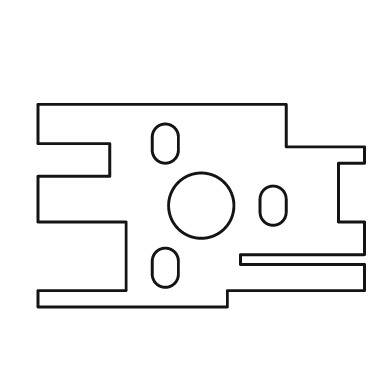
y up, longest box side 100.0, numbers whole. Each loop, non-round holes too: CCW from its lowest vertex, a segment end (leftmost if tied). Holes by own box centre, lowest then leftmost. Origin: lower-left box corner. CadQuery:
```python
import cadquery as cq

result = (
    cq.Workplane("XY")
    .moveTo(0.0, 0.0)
    .lineTo(58.0, 0.0)
    .lineTo(58.0, 5.0)
    .lineTo(100.0, 5.0)
    .lineTo(100.0, 13.0)
    .lineTo(62.0, 13.0)
    .lineTo(62.0, 16.0)
    .lineTo(100.0, 16.0)
    .lineTo(100.0, 26.0)
    .lineTo(92.0, 26.0)
    .lineTo(92.0, 44.0)
    .lineTo(100.0, 44.0)
    .lineTo(100.0, 49.0)
    .lineTo(76.0, 49.0)
    .lineTo(76.0, 62.0)
    .lineTo(0.0, 62.0)
    .lineTo(0.0, 50.0)
    .lineTo(22.0, 50.0)
    .lineTo(22.0, 40.0)
    .lineTo(0.0, 40.0)
    .lineTo(0.0, 26.0)
    .lineTo(27.0, 26.0)
    .lineTo(27.0, 5.0)
    .lineTo(0.0, 5.0)
    .close()
    .moveTo(35.0, 10.0)
    .threePointArc((39.0, 6.0), (43.0, 10.0))
    .lineTo(43.0, 14.0)
    .threePointArc((39.0, 18.0), (35.0, 14.0))
    .close()
    .moveTo(50.0, 31.0)
    .circle(10.0)
    .moveTo(68.0, 29.0)
    .threePointArc((72.0, 25.0), (76.0, 29.0))
    .lineTo(76.0, 33.0)
    .threePointArc((72.0, 37.0), (68.0, 33.0))
    .close()
    .moveTo(35.0, 48.0)
    .threePointArc((39.0, 44.0), (43.0, 48.0))
    .lineTo(43.0, 52.0)
    .threePointArc((39.0, 56.0), (35.0, 52.0))
    .close()
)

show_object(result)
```